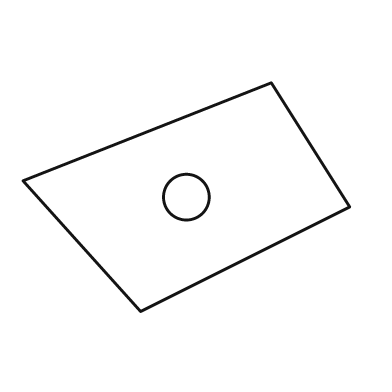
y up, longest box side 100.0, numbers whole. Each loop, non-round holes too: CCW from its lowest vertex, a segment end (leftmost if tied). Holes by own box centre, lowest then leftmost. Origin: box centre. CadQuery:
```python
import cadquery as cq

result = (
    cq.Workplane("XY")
    .moveTo(-14.0, -35.0)
    .lineTo(50.0, -3.0)
    .lineTo(26.0, 35.0)
    .lineTo(-50.0, 5.0)
    .close()
    .moveTo(0.0, 0.0)
    .circle(7.0)
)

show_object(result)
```